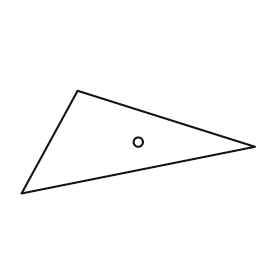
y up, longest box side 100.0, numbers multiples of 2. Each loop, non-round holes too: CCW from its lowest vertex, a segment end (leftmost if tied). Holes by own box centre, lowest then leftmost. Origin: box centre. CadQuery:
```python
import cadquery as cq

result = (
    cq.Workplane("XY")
    .moveTo(-50.0, -22.0)
    .lineTo(50.0, -2.0)
    .lineTo(-26.0, 22.0)
    .close()
    .moveTo(0.0, 0.0)
    .circle(2.0)
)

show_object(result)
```